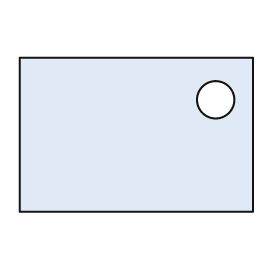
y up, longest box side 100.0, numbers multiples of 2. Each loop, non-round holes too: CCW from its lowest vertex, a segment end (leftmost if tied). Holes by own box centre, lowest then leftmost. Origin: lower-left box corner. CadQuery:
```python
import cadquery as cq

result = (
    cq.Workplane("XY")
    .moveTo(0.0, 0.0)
    .lineTo(100.0, 0.0)
    .lineTo(100.0, 66.0)
    .lineTo(0.0, 66.0)
    .close()
    .moveTo(84.0, 48.0)
    .circle(8.0)
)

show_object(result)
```